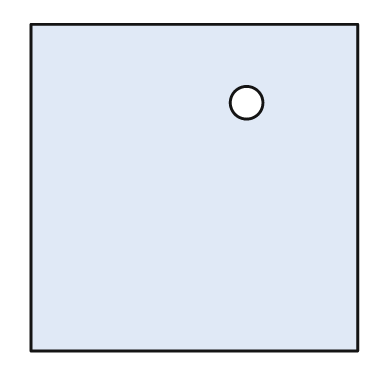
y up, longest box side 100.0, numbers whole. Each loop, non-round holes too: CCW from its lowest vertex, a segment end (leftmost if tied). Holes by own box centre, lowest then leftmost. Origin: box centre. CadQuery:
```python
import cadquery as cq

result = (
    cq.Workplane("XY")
    .moveTo(-50.0, -50.0)
    .lineTo(50.0, -50.0)
    .lineTo(50.0, 50.0)
    .lineTo(-50.0, 50.0)
    .close()
    .moveTo(16.0, 26.0)
    .circle(5.0)
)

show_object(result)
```